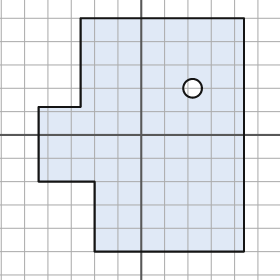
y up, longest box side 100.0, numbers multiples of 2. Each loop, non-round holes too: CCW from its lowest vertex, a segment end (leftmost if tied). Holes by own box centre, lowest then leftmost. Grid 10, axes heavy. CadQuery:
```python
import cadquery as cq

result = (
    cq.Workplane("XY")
    .moveTo(-20.0, -50.0)
    .lineTo(44.0, -50.0)
    .lineTo(44.0, 50.0)
    .lineTo(-26.0, 50.0)
    .lineTo(-26.0, 12.0)
    .lineTo(-44.0, 12.0)
    .lineTo(-44.0, -20.0)
    .lineTo(-20.0, -20.0)
    .close()
    .moveTo(22.0, 20.0)
    .circle(4.0)
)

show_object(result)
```